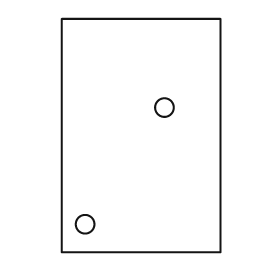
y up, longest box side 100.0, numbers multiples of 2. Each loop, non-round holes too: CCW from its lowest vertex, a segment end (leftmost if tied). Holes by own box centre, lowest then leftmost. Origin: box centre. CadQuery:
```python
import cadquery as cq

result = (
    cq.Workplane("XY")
    .moveTo(-34.0, -50.0)
    .lineTo(34.0, -50.0)
    .lineTo(34.0, 50.0)
    .lineTo(-34.0, 50.0)
    .close()
    .moveTo(-24.0, -38.0)
    .circle(4.0)
    .moveTo(10.0, 12.0)
    .circle(4.0)
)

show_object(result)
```